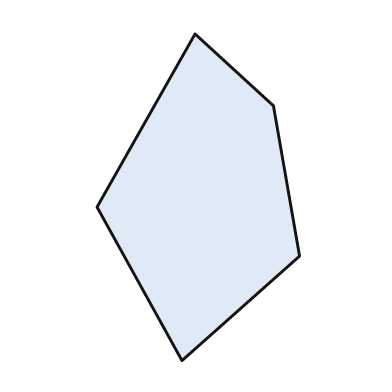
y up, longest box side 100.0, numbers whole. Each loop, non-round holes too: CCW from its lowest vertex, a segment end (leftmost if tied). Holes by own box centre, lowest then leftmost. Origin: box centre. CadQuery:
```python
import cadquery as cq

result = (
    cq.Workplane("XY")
    .moveTo(-5.0, -50.0)
    .lineTo(31.0, -18.0)
    .lineTo(23.0, 28.0)
    .lineTo(-1.0, 50.0)
    .lineTo(-31.0, -3.0)
    .close()
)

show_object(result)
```